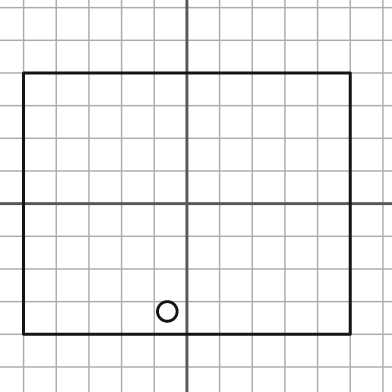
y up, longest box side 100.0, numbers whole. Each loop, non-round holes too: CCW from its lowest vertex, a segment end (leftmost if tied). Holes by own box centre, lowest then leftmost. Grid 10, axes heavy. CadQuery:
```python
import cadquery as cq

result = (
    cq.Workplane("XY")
    .moveTo(-50.0, -40.0)
    .lineTo(50.0, -40.0)
    .lineTo(50.0, 40.0)
    .lineTo(-50.0, 40.0)
    .close()
    .moveTo(-6.0, -33.0)
    .circle(3.0)
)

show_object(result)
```